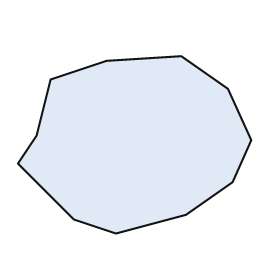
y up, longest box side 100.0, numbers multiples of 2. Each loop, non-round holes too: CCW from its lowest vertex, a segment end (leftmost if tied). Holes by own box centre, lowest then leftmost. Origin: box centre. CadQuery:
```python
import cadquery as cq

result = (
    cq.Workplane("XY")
    .moveTo(-8.0, -38.0)
    .lineTo(22.0, -30.0)
    .lineTo(42.0, -16.0)
    .lineTo(50.0, 2.0)
    .lineTo(40.0, 24.0)
    .lineTo(20.0, 38.0)
    .lineTo(-12.0, 36.0)
    .lineTo(-36.0, 28.0)
    .lineTo(-42.0, 4.0)
    .lineTo(-50.0, -8.0)
    .lineTo(-26.0, -32.0)
    .close()
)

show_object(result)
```